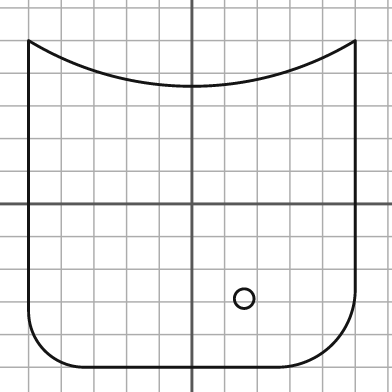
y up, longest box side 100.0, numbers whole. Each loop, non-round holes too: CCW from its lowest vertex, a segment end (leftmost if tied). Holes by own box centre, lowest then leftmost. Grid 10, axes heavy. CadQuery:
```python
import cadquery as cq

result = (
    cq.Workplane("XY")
    .moveTo(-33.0, -50.0)
    .lineTo(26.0, -50.0)
    .threePointArc((43.0, -43.0), (50.0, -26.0))
    .lineTo(50.0, 50.0)
    .threePointArc((0.0, 36.0), (-50.0, 50.0))
    .lineTo(-50.0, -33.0)
    .threePointArc((-45.0, -45.0), (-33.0, -50.0))
    .close()
    .moveTo(16.0, -29.0)
    .circle(3.0)
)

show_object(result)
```